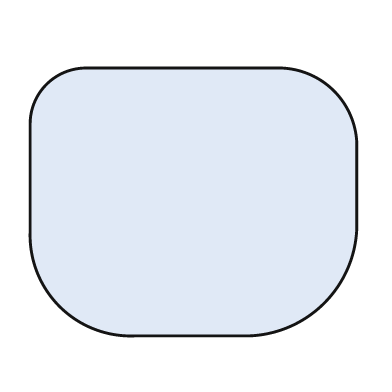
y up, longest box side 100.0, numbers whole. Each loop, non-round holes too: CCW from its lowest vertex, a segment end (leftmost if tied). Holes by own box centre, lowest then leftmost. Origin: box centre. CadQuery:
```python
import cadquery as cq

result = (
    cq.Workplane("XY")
    .moveTo(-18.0, -41.0)
    .lineTo(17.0, -41.0)
    .threePointArc((40.0, -31.0), (50.0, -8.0))
    .lineTo(50.0, 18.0)
    .threePointArc((43.0, 34.0), (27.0, 41.0))
    .lineTo(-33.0, 41.0)
    .threePointArc((-45.0, 36.0), (-50.0, 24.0))
    .lineTo(-50.0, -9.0)
    .threePointArc((-41.0, -32.0), (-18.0, -41.0))
    .close()
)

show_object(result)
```